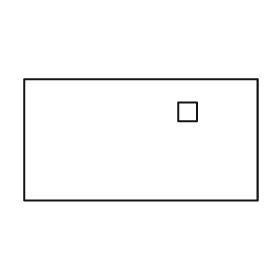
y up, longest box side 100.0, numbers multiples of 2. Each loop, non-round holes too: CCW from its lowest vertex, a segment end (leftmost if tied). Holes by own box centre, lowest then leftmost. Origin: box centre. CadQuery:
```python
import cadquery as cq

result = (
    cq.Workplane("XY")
    .moveTo(-50.0, -26.0)
    .lineTo(50.0, -26.0)
    .lineTo(50.0, 26.0)
    .lineTo(-50.0, 26.0)
    .close()
    .moveTo(16.0, 8.0)
    .lineTo(24.0, 8.0)
    .lineTo(24.0, 16.0)
    .lineTo(16.0, 16.0)
    .close()
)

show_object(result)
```